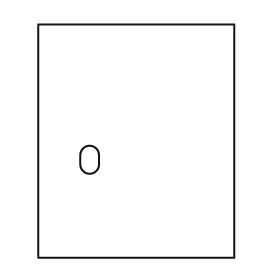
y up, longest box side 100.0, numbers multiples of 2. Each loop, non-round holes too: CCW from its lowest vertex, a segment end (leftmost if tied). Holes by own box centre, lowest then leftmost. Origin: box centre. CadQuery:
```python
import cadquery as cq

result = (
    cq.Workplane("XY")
    .moveTo(-42.0, -50.0)
    .lineTo(42.0, -50.0)
    .lineTo(42.0, 50.0)
    .lineTo(-42.0, 50.0)
    .close()
    .moveTo(-24.0, -10.0)
    .threePointArc((-20.0, -14.0), (-16.0, -10.0))
    .lineTo(-16.0, -6.0)
    .threePointArc((-20.0, -2.0), (-24.0, -6.0))
    .close()
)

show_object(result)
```